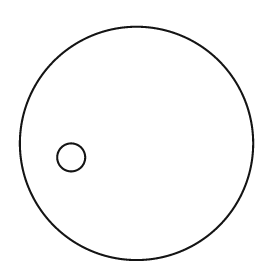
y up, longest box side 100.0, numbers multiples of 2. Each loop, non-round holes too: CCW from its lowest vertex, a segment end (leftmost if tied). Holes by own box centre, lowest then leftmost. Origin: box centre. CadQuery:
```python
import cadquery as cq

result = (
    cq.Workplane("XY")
    .moveTo(0.0, 0.0)
    .circle(50.0)
    .moveTo(-28.0, -6.0)
    .circle(6.0)
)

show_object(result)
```